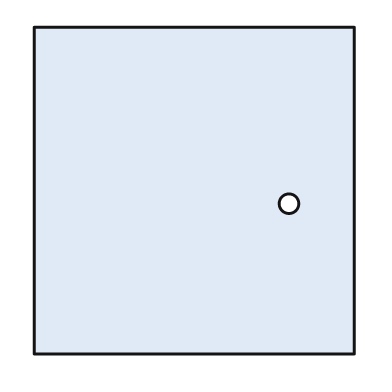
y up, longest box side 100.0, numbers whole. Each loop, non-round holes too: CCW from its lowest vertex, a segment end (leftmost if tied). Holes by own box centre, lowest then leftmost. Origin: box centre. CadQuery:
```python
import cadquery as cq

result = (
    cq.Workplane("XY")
    .moveTo(-49.0, -50.0)
    .lineTo(49.0, -50.0)
    .lineTo(49.0, 50.0)
    .lineTo(-49.0, 50.0)
    .close()
    .moveTo(29.0, -4.0)
    .circle(3.0)
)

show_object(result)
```